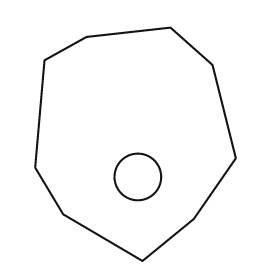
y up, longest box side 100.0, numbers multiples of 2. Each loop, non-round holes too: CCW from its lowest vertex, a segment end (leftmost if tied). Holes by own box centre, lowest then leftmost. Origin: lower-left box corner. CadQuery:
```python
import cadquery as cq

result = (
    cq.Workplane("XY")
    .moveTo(46.0, 0.0)
    .lineTo(68.0, 18.0)
    .lineTo(86.0, 44.0)
    .lineTo(76.0, 84.0)
    .lineTo(58.0, 100.0)
    .lineTo(22.0, 96.0)
    .lineTo(4.0, 86.0)
    .lineTo(0.0, 40.0)
    .lineTo(12.0, 20.0)
    .close()
    .moveTo(44.0, 36.0)
    .circle(10.0)
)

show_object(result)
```